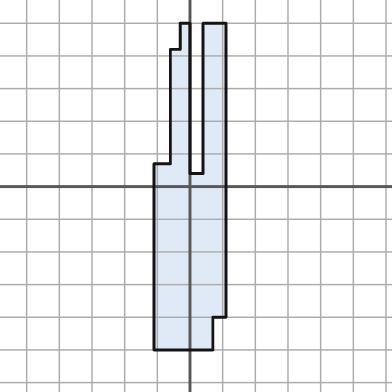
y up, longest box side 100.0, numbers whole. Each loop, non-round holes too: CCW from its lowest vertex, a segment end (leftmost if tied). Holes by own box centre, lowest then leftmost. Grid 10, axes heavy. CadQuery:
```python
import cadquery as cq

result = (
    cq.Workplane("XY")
    .moveTo(-11.0, -50.0)
    .lineTo(7.0, -50.0)
    .lineTo(7.0, -40.0)
    .lineTo(11.0, -40.0)
    .lineTo(11.0, 50.0)
    .lineTo(4.0, 50.0)
    .lineTo(4.0, 4.0)
    .lineTo(0.0, 4.0)
    .lineTo(0.0, 50.0)
    .lineTo(-3.0, 50.0)
    .lineTo(-3.0, 42.0)
    .lineTo(-6.0, 42.0)
    .lineTo(-6.0, 7.0)
    .lineTo(-11.0, 7.0)
    .close()
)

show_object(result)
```